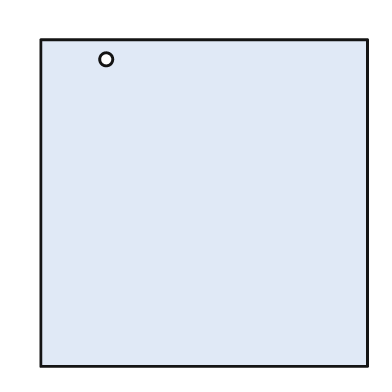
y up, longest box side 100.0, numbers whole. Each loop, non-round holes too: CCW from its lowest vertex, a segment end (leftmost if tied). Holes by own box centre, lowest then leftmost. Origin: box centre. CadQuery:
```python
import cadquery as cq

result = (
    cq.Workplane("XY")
    .moveTo(-50.0, -50.0)
    .lineTo(50.0, -50.0)
    .lineTo(50.0, 50.0)
    .lineTo(-50.0, 50.0)
    .close()
    .moveTo(-30.0, 44.0)
    .circle(2.0)
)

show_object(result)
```